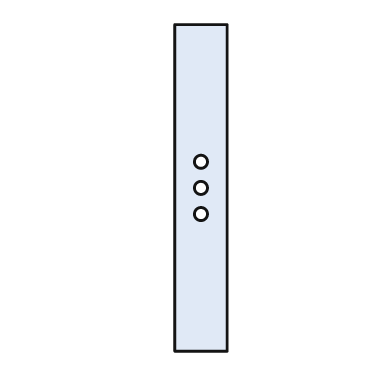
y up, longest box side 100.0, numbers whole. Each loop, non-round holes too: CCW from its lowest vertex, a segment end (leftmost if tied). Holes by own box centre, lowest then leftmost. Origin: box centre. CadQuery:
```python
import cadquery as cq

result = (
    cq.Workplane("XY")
    .moveTo(-8.0, -50.0)
    .lineTo(8.0, -50.0)
    .lineTo(8.0, 50.0)
    .lineTo(-8.0, 50.0)
    .close()
    .moveTo(0.0, -8.0)
    .circle(2.0)
    .moveTo(0.0, 0.0)
    .circle(2.0)
    .moveTo(0.0, 8.0)
    .circle(2.0)
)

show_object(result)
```